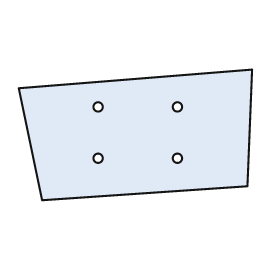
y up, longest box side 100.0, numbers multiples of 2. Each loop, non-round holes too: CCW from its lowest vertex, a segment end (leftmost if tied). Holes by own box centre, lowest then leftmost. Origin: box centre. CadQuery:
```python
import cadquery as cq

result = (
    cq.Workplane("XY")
    .moveTo(-40.0, -28.0)
    .lineTo(48.0, -22.0)
    .lineTo(50.0, 28.0)
    .lineTo(-50.0, 20.0)
    .close()
    .moveTo(-16.0, -10.0)
    .circle(2.0)
    .moveTo(18.0, -10.0)
    .circle(2.0)
    .moveTo(-16.0, 12.0)
    .circle(2.0)
    .moveTo(18.0, 12.0)
    .circle(2.0)
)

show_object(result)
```